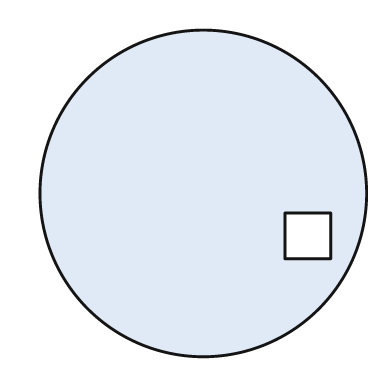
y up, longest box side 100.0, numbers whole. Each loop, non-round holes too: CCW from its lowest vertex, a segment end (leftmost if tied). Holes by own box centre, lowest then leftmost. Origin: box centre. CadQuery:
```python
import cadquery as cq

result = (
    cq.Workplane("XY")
    .moveTo(0.0, 0.0)
    .circle(50.0)
    .moveTo(25.0, -20.0)
    .lineTo(39.0, -20.0)
    .lineTo(39.0, -6.0)
    .lineTo(25.0, -6.0)
    .close()
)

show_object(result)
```